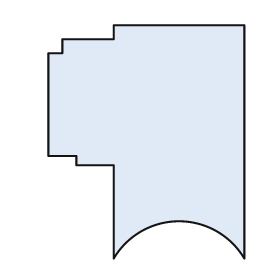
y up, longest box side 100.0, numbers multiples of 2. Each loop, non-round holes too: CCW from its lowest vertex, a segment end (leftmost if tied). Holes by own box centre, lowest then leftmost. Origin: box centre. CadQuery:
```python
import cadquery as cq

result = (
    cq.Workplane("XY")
    .moveTo(-14.0, -50.0)
    .threePointArc((14.0, -34.0), (42.0, -50.0))
    .lineTo(42.0, 50.0)
    .lineTo(-14.0, 50.0)
    .lineTo(-14.0, 44.0)
    .lineTo(-36.0, 44.0)
    .lineTo(-36.0, 38.0)
    .lineTo(-42.0, 38.0)
    .lineTo(-42.0, -6.0)
    .lineTo(-30.0, -6.0)
    .lineTo(-30.0, -10.0)
    .lineTo(-14.0, -10.0)
    .close()
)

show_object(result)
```